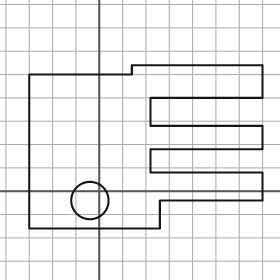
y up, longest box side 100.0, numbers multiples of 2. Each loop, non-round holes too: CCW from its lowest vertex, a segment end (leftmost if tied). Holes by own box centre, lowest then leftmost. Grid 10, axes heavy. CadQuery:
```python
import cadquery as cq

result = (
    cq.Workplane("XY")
    .moveTo(-30.0, -16.0)
    .lineTo(26.0, -16.0)
    .lineTo(26.0, -4.0)
    .lineTo(70.0, -4.0)
    .lineTo(70.0, 8.0)
    .lineTo(22.0, 8.0)
    .lineTo(22.0, 18.0)
    .lineTo(70.0, 18.0)
    .lineTo(70.0, 28.0)
    .lineTo(22.0, 28.0)
    .lineTo(22.0, 40.0)
    .lineTo(70.0, 40.0)
    .lineTo(70.0, 54.0)
    .lineTo(14.0, 54.0)
    .lineTo(14.0, 50.0)
    .lineTo(-30.0, 50.0)
    .close()
    .moveTo(-4.0, -4.0)
    .circle(8.0)
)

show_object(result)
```